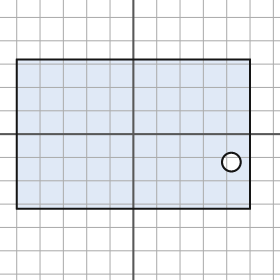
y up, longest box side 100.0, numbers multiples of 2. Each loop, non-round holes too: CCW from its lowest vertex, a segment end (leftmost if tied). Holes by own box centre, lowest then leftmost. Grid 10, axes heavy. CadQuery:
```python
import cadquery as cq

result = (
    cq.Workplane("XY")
    .moveTo(-50.0, -32.0)
    .lineTo(50.0, -32.0)
    .lineTo(50.0, 32.0)
    .lineTo(-50.0, 32.0)
    .close()
    .moveTo(42.0, -12.0)
    .circle(4.0)
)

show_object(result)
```